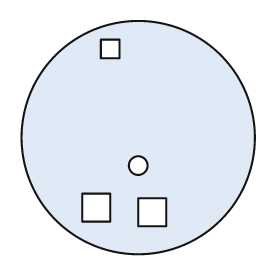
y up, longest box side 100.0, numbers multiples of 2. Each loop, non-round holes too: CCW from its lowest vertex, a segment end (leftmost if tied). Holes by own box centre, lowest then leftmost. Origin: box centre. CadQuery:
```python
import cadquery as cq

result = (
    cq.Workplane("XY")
    .moveTo(0.0, 0.0)
    .circle(50.0)
    .moveTo(0.0, -38.0)
    .lineTo(12.0, -38.0)
    .lineTo(12.0, -26.0)
    .lineTo(0.0, -26.0)
    .close()
    .moveTo(-24.0, -36.0)
    .lineTo(-12.0, -36.0)
    .lineTo(-12.0, -24.0)
    .lineTo(-24.0, -24.0)
    .close()
    .moveTo(0.0, -12.0)
    .circle(4.0)
    .moveTo(-16.0, 34.0)
    .lineTo(-8.0, 34.0)
    .lineTo(-8.0, 42.0)
    .lineTo(-16.0, 42.0)
    .close()
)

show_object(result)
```